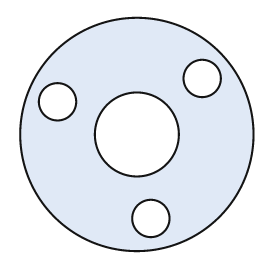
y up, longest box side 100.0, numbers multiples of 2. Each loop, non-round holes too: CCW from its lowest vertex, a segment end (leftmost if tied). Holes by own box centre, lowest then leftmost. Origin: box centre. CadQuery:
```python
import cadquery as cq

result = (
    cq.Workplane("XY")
    .moveTo(0.0, 0.0)
    .circle(50.0)
    .moveTo(6.0, -36.0)
    .circle(8.0)
    .moveTo(0.0, 0.0)
    .circle(18.0)
    .moveTo(-34.0, 14.0)
    .circle(8.0)
    .moveTo(28.0, 24.0)
    .circle(8.0)
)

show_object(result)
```